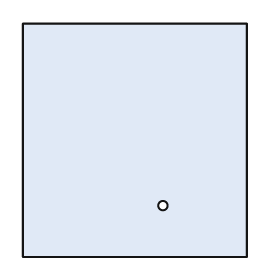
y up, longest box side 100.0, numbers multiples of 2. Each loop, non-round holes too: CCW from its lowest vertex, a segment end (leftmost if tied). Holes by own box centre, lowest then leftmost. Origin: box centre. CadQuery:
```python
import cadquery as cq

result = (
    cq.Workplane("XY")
    .moveTo(-48.0, -50.0)
    .lineTo(48.0, -50.0)
    .lineTo(48.0, 50.0)
    .lineTo(-48.0, 50.0)
    .close()
    .moveTo(12.0, -28.0)
    .circle(2.0)
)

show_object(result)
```